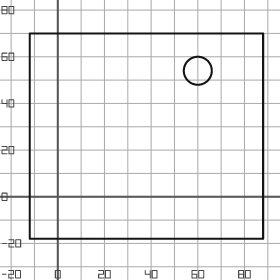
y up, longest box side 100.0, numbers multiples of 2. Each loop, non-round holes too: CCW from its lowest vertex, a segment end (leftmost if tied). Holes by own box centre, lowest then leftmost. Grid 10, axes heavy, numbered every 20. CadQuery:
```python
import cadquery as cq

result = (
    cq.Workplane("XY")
    .moveTo(-12.0, -18.0)
    .lineTo(88.0, -18.0)
    .lineTo(88.0, 70.0)
    .lineTo(-12.0, 70.0)
    .close()
    .moveTo(60.0, 54.0)
    .circle(6.0)
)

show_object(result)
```